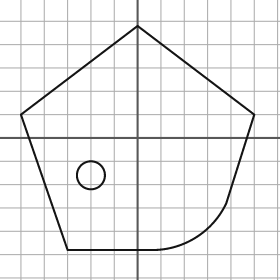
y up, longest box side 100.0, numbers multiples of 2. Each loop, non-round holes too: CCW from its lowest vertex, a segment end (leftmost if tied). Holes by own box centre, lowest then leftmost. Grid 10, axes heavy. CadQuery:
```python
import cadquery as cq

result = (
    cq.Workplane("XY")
    .moveTo(-30.0, -48.0)
    .lineTo(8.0, -48.0)
    .threePointArc((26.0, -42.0), (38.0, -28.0))
    .lineTo(50.0, 10.0)
    .lineTo(0.0, 48.0)
    .lineTo(-50.0, 10.0)
    .close()
    .moveTo(-20.0, -16.0)
    .circle(6.0)
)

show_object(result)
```